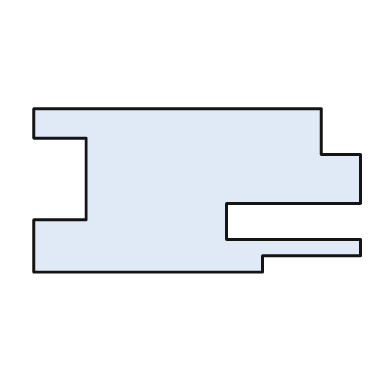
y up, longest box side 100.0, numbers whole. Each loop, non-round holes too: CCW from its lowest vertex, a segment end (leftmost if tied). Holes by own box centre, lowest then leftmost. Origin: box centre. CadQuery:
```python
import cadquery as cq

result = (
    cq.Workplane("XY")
    .moveTo(-50.0, -25.0)
    .lineTo(20.0, -25.0)
    .lineTo(20.0, -20.0)
    .lineTo(50.0, -20.0)
    .lineTo(50.0, -15.0)
    .lineTo(9.0, -15.0)
    .lineTo(9.0, -4.0)
    .lineTo(50.0, -4.0)
    .lineTo(50.0, 11.0)
    .lineTo(38.0, 11.0)
    .lineTo(38.0, 25.0)
    .lineTo(-50.0, 25.0)
    .lineTo(-50.0, 16.0)
    .lineTo(-34.0, 16.0)
    .lineTo(-34.0, -9.0)
    .lineTo(-50.0, -9.0)
    .close()
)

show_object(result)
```